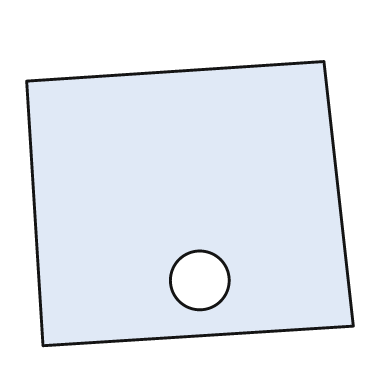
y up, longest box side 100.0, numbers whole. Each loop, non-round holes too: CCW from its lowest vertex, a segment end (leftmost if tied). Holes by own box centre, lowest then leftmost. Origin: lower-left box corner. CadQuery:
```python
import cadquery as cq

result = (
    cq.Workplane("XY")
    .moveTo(5.0, 0.0)
    .lineTo(100.0, 6.0)
    .lineTo(91.0, 87.0)
    .lineTo(0.0, 81.0)
    .close()
    .moveTo(53.0, 20.0)
    .circle(9.0)
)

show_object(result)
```